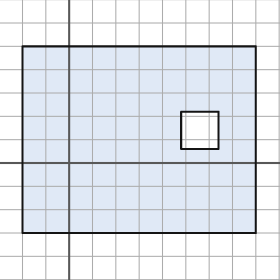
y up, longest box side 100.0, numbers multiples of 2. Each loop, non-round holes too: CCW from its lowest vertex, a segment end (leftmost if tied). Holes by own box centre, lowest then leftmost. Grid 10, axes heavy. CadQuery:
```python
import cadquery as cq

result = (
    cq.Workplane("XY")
    .moveTo(-20.0, -30.0)
    .lineTo(80.0, -30.0)
    .lineTo(80.0, 50.0)
    .lineTo(-20.0, 50.0)
    .close()
    .moveTo(48.0, 6.0)
    .lineTo(64.0, 6.0)
    .lineTo(64.0, 22.0)
    .lineTo(48.0, 22.0)
    .close()
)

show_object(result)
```